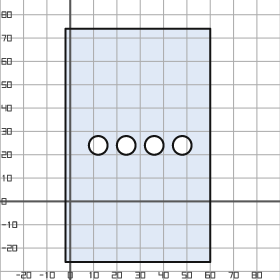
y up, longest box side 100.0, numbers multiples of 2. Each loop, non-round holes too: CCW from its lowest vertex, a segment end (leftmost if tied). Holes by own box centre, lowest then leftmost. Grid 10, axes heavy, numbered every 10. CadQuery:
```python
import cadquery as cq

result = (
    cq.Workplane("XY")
    .moveTo(-2.0, -26.0)
    .lineTo(60.0, -26.0)
    .lineTo(60.0, 74.0)
    .lineTo(-2.0, 74.0)
    .close()
    .moveTo(12.0, 24.0)
    .circle(4.0)
    .moveTo(24.0, 24.0)
    .circle(4.0)
    .moveTo(36.0, 24.0)
    .circle(4.0)
    .moveTo(48.0, 24.0)
    .circle(4.0)
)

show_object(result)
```